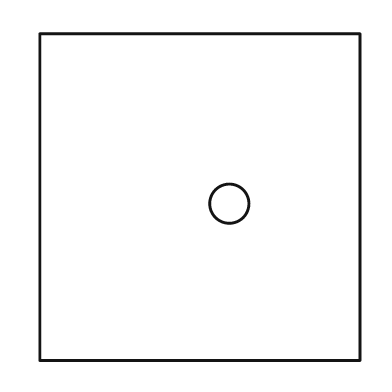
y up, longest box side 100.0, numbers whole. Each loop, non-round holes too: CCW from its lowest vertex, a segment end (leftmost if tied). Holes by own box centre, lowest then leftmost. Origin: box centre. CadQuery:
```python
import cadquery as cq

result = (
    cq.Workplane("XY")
    .moveTo(-49.0, -50.0)
    .lineTo(49.0, -50.0)
    .lineTo(49.0, 50.0)
    .lineTo(-49.0, 50.0)
    .close()
    .moveTo(9.0, -2.0)
    .circle(6.0)
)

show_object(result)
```